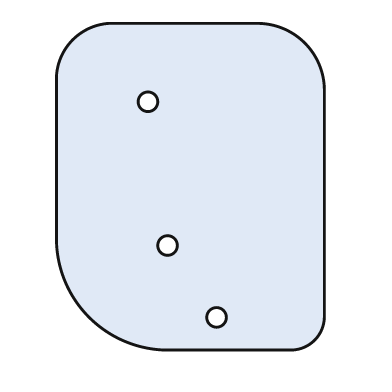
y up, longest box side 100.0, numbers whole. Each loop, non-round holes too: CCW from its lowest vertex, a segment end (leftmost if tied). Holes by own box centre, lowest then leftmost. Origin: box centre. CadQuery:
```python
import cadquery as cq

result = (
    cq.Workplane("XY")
    .moveTo(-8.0, -50.0)
    .lineTo(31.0, -50.0)
    .threePointArc((38.0, -47.0), (41.0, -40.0))
    .lineTo(41.0, 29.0)
    .threePointArc((35.0, 44.0), (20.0, 50.0))
    .lineTo(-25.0, 50.0)
    .threePointArc((-36.0, 45.0), (-41.0, 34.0))
    .lineTo(-41.0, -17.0)
    .threePointArc((-31.0, -40.0), (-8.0, -50.0))
    .close()
    .moveTo(8.0, -40.0)
    .circle(3.0)
    .moveTo(-7.0, -18.0)
    .circle(3.0)
    .moveTo(-13.0, 26.0)
    .circle(3.0)
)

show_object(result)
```